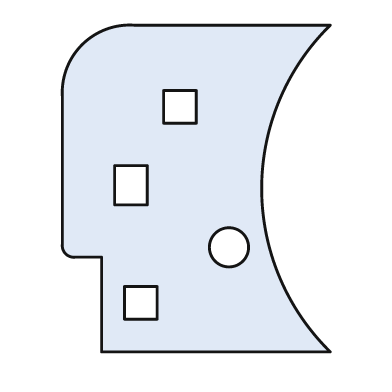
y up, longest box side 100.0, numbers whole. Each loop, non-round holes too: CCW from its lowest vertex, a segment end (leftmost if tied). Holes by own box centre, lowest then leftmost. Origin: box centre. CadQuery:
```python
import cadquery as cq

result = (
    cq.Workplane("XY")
    .moveTo(-29.0, -50.0)
    .lineTo(41.0, -50.0)
    .threePointArc((20.0, 0.0), (41.0, 50.0))
    .lineTo(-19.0, 50.0)
    .threePointArc((-35.0, 44.0), (-41.0, 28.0))
    .lineTo(-41.0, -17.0)
    .threePointArc((-40.0, -20.0), (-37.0, -21.0))
    .lineTo(-29.0, -21.0)
    .close()
    .moveTo(-22.0, -40.0)
    .lineTo(-12.0, -40.0)
    .lineTo(-12.0, -30.0)
    .lineTo(-22.0, -30.0)
    .close()
    .moveTo(10.0, -18.0)
    .circle(6.0)
    .moveTo(-25.0, -5.0)
    .lineTo(-15.0, -5.0)
    .lineTo(-15.0, 7.0)
    .lineTo(-25.0, 7.0)
    .close()
    .moveTo(-10.0, 20.0)
    .lineTo(0.0, 20.0)
    .lineTo(0.0, 30.0)
    .lineTo(-10.0, 30.0)
    .close()
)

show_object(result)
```